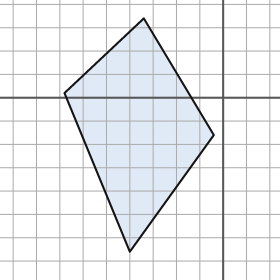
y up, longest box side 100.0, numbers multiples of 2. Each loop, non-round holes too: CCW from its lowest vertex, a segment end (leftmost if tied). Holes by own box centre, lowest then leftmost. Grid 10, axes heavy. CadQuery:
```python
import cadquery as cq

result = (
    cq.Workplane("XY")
    .moveTo(-40.0, -66.0)
    .lineTo(-4.0, -16.0)
    .lineTo(-34.0, 34.0)
    .lineTo(-68.0, 2.0)
    .close()
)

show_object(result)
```